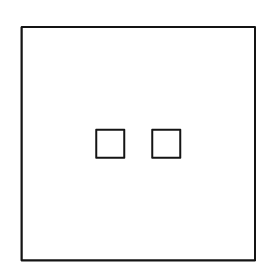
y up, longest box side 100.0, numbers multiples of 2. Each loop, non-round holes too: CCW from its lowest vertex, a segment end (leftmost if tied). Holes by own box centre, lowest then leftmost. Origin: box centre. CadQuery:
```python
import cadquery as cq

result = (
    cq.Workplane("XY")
    .moveTo(-50.0, -50.0)
    .lineTo(50.0, -50.0)
    .lineTo(50.0, 50.0)
    .lineTo(-50.0, 50.0)
    .close()
    .moveTo(-18.0, -6.0)
    .lineTo(-6.0, -6.0)
    .lineTo(-6.0, 6.0)
    .lineTo(-18.0, 6.0)
    .close()
    .moveTo(6.0, -6.0)
    .lineTo(18.0, -6.0)
    .lineTo(18.0, 6.0)
    .lineTo(6.0, 6.0)
    .close()
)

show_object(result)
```